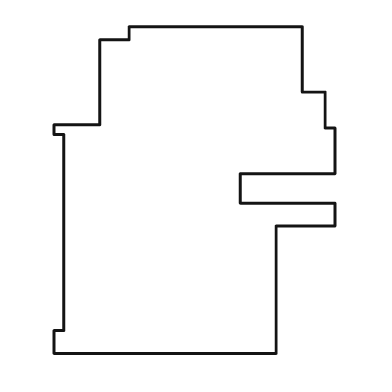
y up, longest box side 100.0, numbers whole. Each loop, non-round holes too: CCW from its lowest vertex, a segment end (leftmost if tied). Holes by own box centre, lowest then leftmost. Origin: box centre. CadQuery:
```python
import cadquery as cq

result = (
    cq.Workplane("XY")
    .moveTo(-43.0, -50.0)
    .lineTo(25.0, -50.0)
    .lineTo(25.0, -11.0)
    .lineTo(43.0, -11.0)
    .lineTo(43.0, -4.0)
    .lineTo(14.0, -4.0)
    .lineTo(14.0, 5.0)
    .lineTo(43.0, 5.0)
    .lineTo(43.0, 19.0)
    .lineTo(40.0, 19.0)
    .lineTo(40.0, 30.0)
    .lineTo(33.0, 30.0)
    .lineTo(33.0, 50.0)
    .lineTo(-20.0, 50.0)
    .lineTo(-20.0, 46.0)
    .lineTo(-29.0, 46.0)
    .lineTo(-29.0, 20.0)
    .lineTo(-43.0, 20.0)
    .lineTo(-43.0, 17.0)
    .lineTo(-40.0, 17.0)
    .lineTo(-40.0, -43.0)
    .lineTo(-43.0, -43.0)
    .close()
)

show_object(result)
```